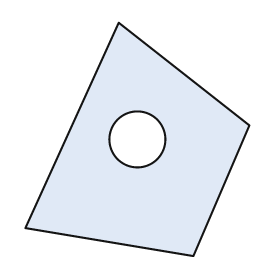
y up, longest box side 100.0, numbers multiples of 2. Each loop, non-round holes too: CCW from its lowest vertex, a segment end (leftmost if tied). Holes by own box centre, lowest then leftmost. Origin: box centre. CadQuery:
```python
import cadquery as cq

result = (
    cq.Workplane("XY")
    .moveTo(24.0, -50.0)
    .lineTo(48.0, 6.0)
    .lineTo(-8.0, 50.0)
    .lineTo(-48.0, -38.0)
    .close()
    .moveTo(0.0, 0.0)
    .circle(12.0)
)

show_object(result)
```